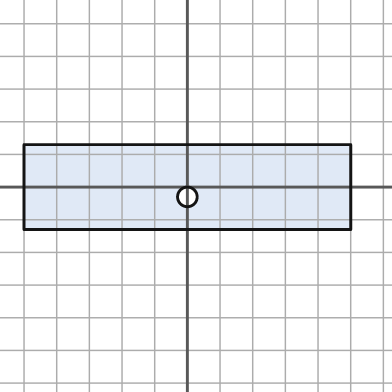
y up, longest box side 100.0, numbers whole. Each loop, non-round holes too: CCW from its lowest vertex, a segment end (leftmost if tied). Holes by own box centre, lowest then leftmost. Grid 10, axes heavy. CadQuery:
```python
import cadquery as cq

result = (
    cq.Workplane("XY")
    .moveTo(-50.0, -13.0)
    .lineTo(50.0, -13.0)
    .lineTo(50.0, 13.0)
    .lineTo(-50.0, 13.0)
    .close()
    .moveTo(0.0, -3.0)
    .circle(3.0)
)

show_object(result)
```